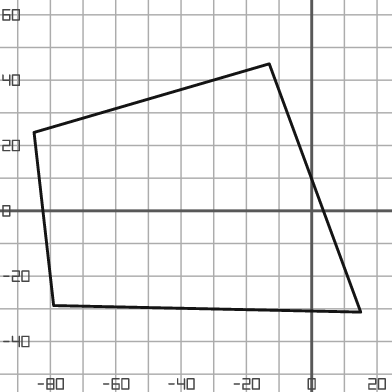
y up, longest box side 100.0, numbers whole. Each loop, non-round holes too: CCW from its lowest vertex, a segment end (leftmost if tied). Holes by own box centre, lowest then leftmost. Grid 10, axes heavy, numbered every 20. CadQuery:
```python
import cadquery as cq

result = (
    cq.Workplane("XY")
    .moveTo(15.0, -31.0)
    .lineTo(-13.0, 45.0)
    .lineTo(-85.0, 24.0)
    .lineTo(-79.0, -29.0)
    .close()
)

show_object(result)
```